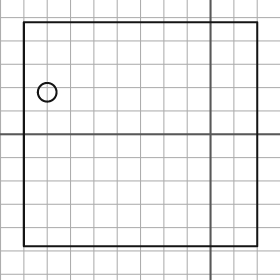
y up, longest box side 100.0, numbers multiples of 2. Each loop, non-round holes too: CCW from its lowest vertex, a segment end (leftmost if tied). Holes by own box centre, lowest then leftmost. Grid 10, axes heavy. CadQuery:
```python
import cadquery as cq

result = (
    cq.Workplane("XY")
    .moveTo(-80.0, -48.0)
    .lineTo(20.0, -48.0)
    .lineTo(20.0, 48.0)
    .lineTo(-80.0, 48.0)
    .close()
    .moveTo(-70.0, 18.0)
    .circle(4.0)
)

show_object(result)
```